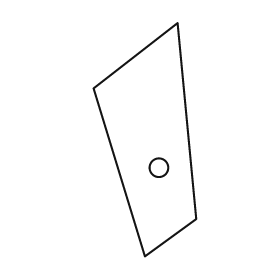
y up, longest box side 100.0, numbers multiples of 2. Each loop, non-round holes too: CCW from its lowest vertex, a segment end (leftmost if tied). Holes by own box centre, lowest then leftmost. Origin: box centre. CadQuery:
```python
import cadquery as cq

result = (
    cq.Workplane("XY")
    .moveTo(0.0, -50.0)
    .lineTo(22.0, -34.0)
    .lineTo(14.0, 50.0)
    .lineTo(-22.0, 22.0)
    .close()
    .moveTo(6.0, -12.0)
    .circle(4.0)
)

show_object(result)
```